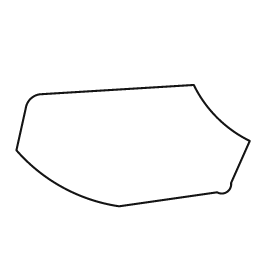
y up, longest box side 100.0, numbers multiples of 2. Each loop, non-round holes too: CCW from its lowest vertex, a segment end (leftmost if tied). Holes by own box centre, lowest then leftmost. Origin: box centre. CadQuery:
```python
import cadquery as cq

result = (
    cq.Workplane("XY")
    .moveTo(-6.0, -26.0)
    .lineTo(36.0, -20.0)
    .threePointArc((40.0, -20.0), (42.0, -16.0))
    .lineTo(50.0, 2.0)
    .threePointArc((36.0, 12.0), (26.0, 26.0))
    .lineTo(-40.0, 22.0)
    .threePointArc((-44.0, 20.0), (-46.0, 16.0))
    .lineTo(-50.0, -2.0)
    .threePointArc((-30.0, -18.0), (-6.0, -26.0))
    .close()
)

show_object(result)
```